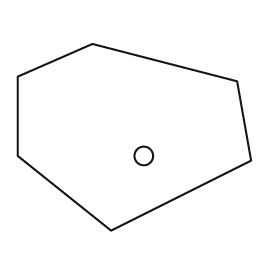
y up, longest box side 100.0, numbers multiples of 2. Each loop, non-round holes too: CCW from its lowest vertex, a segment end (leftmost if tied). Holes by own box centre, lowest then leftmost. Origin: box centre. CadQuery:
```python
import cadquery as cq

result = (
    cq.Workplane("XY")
    .moveTo(-10.0, -40.0)
    .lineTo(50.0, -10.0)
    .lineTo(44.0, 24.0)
    .lineTo(-18.0, 40.0)
    .lineTo(-50.0, 26.0)
    .lineTo(-50.0, -8.0)
    .close()
    .moveTo(4.0, -8.0)
    .circle(4.0)
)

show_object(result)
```